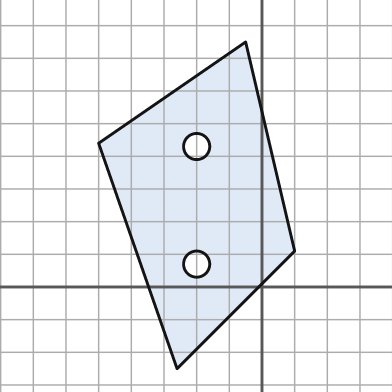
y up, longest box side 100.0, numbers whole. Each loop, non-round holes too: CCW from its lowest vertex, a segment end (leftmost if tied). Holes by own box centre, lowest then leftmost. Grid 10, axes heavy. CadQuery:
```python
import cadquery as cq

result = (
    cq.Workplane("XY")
    .moveTo(-26.0, -25.0)
    .lineTo(10.0, 11.0)
    .lineTo(-5.0, 75.0)
    .lineTo(-50.0, 44.0)
    .close()
    .moveTo(-20.0, 7.0)
    .circle(4.0)
    .moveTo(-20.0, 43.0)
    .circle(4.0)
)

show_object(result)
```